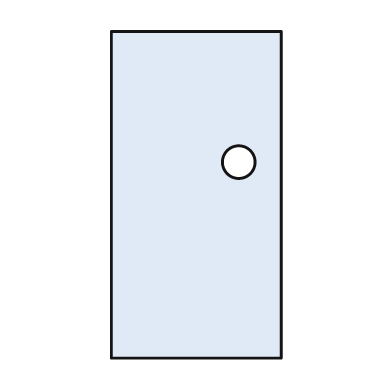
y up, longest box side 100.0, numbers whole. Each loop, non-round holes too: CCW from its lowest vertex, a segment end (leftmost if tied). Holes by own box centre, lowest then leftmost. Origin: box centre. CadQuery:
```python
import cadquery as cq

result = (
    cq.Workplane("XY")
    .moveTo(-26.0, -50.0)
    .lineTo(26.0, -50.0)
    .lineTo(26.0, 50.0)
    .lineTo(-26.0, 50.0)
    .close()
    .moveTo(13.0, 10.0)
    .circle(5.0)
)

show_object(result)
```